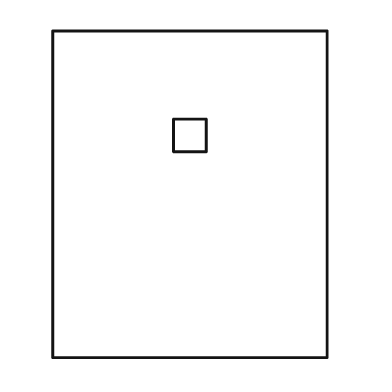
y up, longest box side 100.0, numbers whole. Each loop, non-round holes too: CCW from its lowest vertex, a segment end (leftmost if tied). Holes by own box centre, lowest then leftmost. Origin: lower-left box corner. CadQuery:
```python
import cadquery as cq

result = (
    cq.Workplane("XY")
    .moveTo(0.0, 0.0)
    .lineTo(84.0, 0.0)
    .lineTo(84.0, 100.0)
    .lineTo(0.0, 100.0)
    .close()
    .moveTo(37.0, 63.0)
    .lineTo(47.0, 63.0)
    .lineTo(47.0, 73.0)
    .lineTo(37.0, 73.0)
    .close()
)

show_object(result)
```